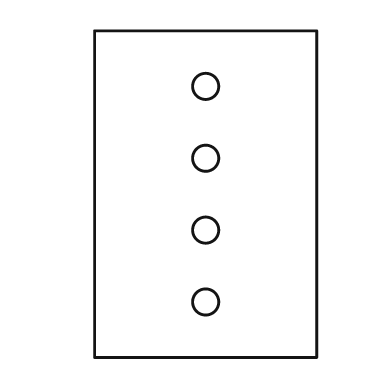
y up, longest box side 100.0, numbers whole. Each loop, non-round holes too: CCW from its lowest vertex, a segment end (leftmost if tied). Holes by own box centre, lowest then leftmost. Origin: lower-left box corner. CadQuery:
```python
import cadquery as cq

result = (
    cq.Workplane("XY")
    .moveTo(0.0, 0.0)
    .lineTo(68.0, 0.0)
    .lineTo(68.0, 100.0)
    .lineTo(0.0, 100.0)
    .close()
    .moveTo(34.0, 17.0)
    .circle(4.0)
    .moveTo(34.0, 39.0)
    .circle(4.0)
    .moveTo(34.0, 61.0)
    .circle(4.0)
    .moveTo(34.0, 83.0)
    .circle(4.0)
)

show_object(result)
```